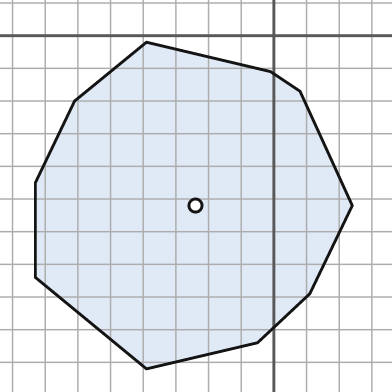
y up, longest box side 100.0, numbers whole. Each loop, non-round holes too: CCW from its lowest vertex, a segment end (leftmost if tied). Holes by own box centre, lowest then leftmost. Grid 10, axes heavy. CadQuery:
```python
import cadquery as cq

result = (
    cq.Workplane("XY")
    .moveTo(-39.0, -102.0)
    .lineTo(-5.0, -94.0)
    .lineTo(11.0, -79.0)
    .lineTo(24.0, -52.0)
    .lineTo(8.0, -17.0)
    .lineTo(-1.0, -11.0)
    .lineTo(-39.0, -2.0)
    .lineTo(-61.0, -20.0)
    .lineTo(-73.0, -45.0)
    .lineTo(-73.0, -74.0)
    .close()
    .moveTo(-24.0, -52.0)
    .circle(2.0)
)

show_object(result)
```